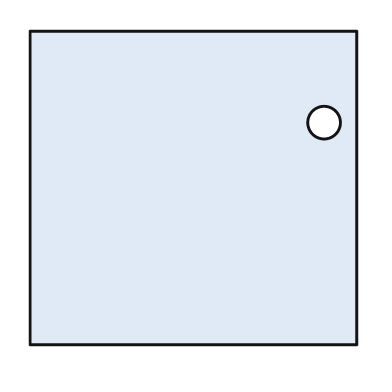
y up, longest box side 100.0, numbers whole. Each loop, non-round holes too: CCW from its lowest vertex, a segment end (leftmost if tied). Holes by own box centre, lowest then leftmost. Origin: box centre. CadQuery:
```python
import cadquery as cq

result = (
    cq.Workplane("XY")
    .moveTo(-50.0, -48.0)
    .lineTo(50.0, -48.0)
    .lineTo(50.0, 48.0)
    .lineTo(-50.0, 48.0)
    .close()
    .moveTo(40.0, 20.0)
    .circle(5.0)
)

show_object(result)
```